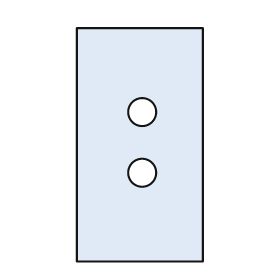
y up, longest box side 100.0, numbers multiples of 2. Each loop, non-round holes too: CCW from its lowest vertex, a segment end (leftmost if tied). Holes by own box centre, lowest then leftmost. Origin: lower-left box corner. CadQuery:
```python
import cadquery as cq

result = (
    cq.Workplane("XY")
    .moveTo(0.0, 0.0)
    .lineTo(54.0, 0.0)
    .lineTo(54.0, 100.0)
    .lineTo(0.0, 100.0)
    .close()
    .moveTo(28.0, 38.0)
    .circle(6.0)
    .moveTo(28.0, 64.0)
    .circle(6.0)
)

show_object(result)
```